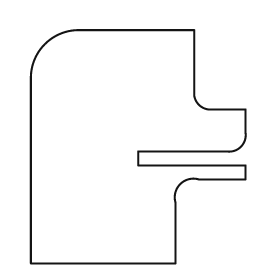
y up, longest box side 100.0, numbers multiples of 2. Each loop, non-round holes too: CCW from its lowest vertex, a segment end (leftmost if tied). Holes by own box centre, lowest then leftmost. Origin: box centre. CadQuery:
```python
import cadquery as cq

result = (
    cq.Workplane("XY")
    .moveTo(-46.0, -50.0)
    .lineTo(16.0, -50.0)
    .lineTo(16.0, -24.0)
    .threePointArc((18.0, -16.0), (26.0, -14.0))
    .lineTo(46.0, -14.0)
    .lineTo(46.0, -8.0)
    .lineTo(0.0, -8.0)
    .lineTo(0.0, -2.0)
    .lineTo(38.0, -2.0)
    .threePointArc((44.0, 0.0), (46.0, 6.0))
    .lineTo(46.0, 16.0)
    .lineTo(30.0, 16.0)
    .threePointArc((26.0, 18.0), (24.0, 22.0))
    .lineTo(24.0, 50.0)
    .lineTo(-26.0, 50.0)
    .threePointArc((-40.0, 44.0), (-46.0, 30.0))
    .close()
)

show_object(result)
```